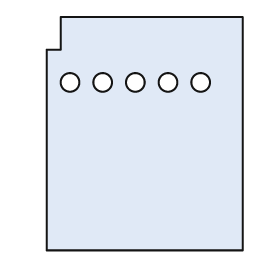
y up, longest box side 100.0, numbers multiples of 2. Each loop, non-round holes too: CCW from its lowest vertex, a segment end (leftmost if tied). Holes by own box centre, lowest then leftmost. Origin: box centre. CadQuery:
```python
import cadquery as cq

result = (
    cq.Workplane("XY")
    .moveTo(-42.0, -50.0)
    .lineTo(42.0, -50.0)
    .lineTo(42.0, 50.0)
    .lineTo(-36.0, 50.0)
    .lineTo(-36.0, 36.0)
    .lineTo(-42.0, 36.0)
    .close()
    .moveTo(-32.0, 22.0)
    .circle(4.0)
    .moveTo(-18.0, 22.0)
    .circle(4.0)
    .moveTo(-4.0, 22.0)
    .circle(4.0)
    .moveTo(10.0, 22.0)
    .circle(4.0)
    .moveTo(24.0, 22.0)
    .circle(4.0)
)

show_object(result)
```